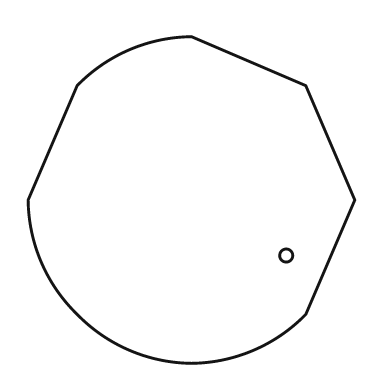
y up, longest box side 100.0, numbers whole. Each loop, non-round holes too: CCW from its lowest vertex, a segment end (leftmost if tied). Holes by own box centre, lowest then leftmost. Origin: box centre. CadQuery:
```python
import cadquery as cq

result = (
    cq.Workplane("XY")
    .moveTo(0.0, -50.0)
    .threePointArc((19.0, -46.0), (35.0, -35.0))
    .lineTo(50.0, 0.0)
    .lineTo(35.0, 35.0)
    .lineTo(0.0, 50.0)
    .threePointArc((-19.0, 46.0), (-35.0, 35.0))
    .lineTo(-50.0, 0.0)
    .threePointArc((-46.0, -19.0), (-35.0, -35.0))
    .threePointArc((-19.0, -46.0), (0.0, -50.0))
    .close()
    .moveTo(29.0, -17.0)
    .circle(2.0)
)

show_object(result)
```